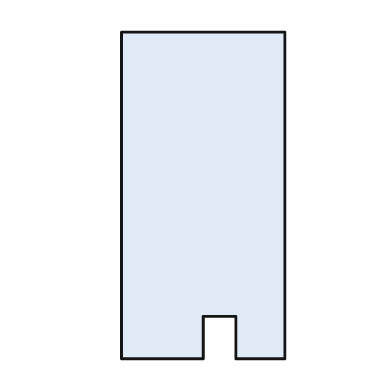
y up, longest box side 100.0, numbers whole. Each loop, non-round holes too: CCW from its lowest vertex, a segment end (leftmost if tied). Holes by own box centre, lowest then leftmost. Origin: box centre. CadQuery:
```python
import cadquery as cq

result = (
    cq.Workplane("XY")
    .moveTo(-25.0, -50.0)
    .lineTo(0.0, -50.0)
    .lineTo(0.0, -37.0)
    .lineTo(10.0, -37.0)
    .lineTo(10.0, -50.0)
    .lineTo(25.0, -50.0)
    .lineTo(25.0, 50.0)
    .lineTo(-25.0, 50.0)
    .close()
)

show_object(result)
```